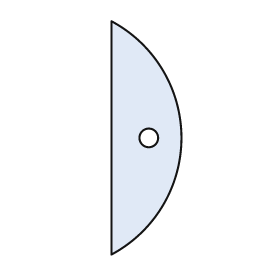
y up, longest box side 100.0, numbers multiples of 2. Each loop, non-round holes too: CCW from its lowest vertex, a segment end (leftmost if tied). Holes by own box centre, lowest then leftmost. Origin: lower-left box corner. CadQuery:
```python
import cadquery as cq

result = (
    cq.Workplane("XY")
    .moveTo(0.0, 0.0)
    .threePointArc((30.0, 50.0), (0.0, 100.0))
    .close()
    .moveTo(16.0, 50.0)
    .circle(4.0)
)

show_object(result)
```